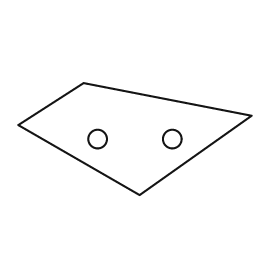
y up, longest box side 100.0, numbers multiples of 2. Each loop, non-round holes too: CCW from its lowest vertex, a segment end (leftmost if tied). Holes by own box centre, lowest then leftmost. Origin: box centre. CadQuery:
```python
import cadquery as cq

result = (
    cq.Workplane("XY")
    .moveTo(2.0, -24.0)
    .lineTo(50.0, 10.0)
    .lineTo(-22.0, 24.0)
    .lineTo(-50.0, 6.0)
    .close()
    .moveTo(-16.0, 0.0)
    .circle(4.0)
    .moveTo(16.0, 0.0)
    .circle(4.0)
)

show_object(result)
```